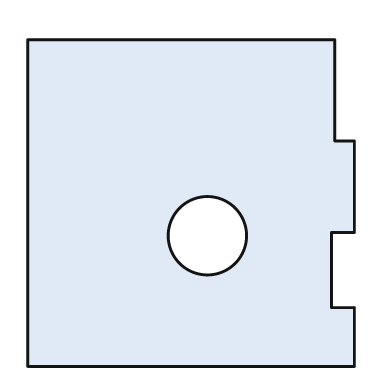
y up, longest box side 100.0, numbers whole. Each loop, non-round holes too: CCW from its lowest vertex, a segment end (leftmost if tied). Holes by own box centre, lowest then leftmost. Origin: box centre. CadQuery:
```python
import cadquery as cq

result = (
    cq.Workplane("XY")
    .moveTo(-50.0, -50.0)
    .lineTo(50.0, -50.0)
    .lineTo(50.0, -32.0)
    .lineTo(43.0, -32.0)
    .lineTo(43.0, -9.0)
    .lineTo(50.0, -9.0)
    .lineTo(50.0, 19.0)
    .lineTo(44.0, 19.0)
    .lineTo(44.0, 50.0)
    .lineTo(-50.0, 50.0)
    .close()
    .moveTo(5.0, -10.0)
    .circle(12.0)
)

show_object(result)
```